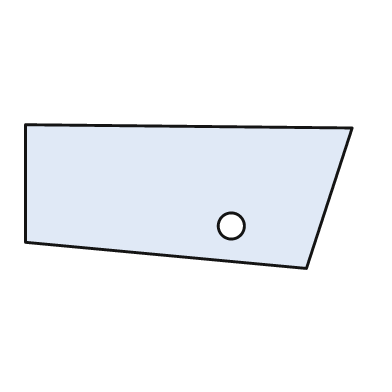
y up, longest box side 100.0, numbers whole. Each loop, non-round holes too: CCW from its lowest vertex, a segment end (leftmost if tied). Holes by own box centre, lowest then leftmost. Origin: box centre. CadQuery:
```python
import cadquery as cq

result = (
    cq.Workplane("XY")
    .moveTo(36.0, -22.0)
    .lineTo(50.0, 21.0)
    .lineTo(-50.0, 22.0)
    .lineTo(-50.0, -14.0)
    .close()
    .moveTo(13.0, -9.0)
    .circle(4.0)
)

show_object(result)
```